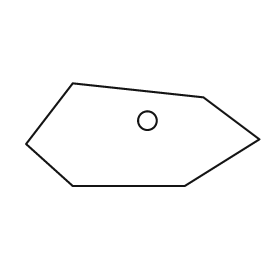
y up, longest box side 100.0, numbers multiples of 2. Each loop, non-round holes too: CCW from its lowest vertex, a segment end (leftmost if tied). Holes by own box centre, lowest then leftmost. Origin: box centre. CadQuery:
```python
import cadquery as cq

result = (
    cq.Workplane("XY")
    .moveTo(-30.0, -22.0)
    .lineTo(18.0, -22.0)
    .lineTo(50.0, -2.0)
    .lineTo(26.0, 16.0)
    .lineTo(-30.0, 22.0)
    .lineTo(-50.0, -4.0)
    .close()
    .moveTo(2.0, 6.0)
    .circle(4.0)
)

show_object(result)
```